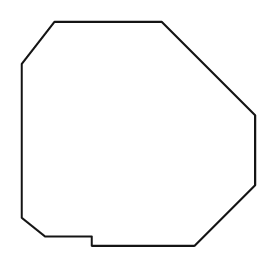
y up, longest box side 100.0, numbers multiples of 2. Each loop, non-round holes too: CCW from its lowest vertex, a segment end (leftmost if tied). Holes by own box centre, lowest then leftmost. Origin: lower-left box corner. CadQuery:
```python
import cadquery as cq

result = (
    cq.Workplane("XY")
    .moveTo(30.0, 0.0)
    .lineTo(74.0, 0.0)
    .lineTo(100.0, 26.0)
    .lineTo(100.0, 56.0)
    .lineTo(60.0, 96.0)
    .lineTo(14.0, 96.0)
    .lineTo(0.0, 78.0)
    .lineTo(0.0, 12.0)
    .lineTo(10.0, 4.0)
    .lineTo(30.0, 4.0)
    .close()
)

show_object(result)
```